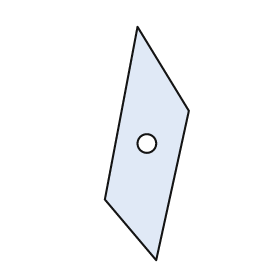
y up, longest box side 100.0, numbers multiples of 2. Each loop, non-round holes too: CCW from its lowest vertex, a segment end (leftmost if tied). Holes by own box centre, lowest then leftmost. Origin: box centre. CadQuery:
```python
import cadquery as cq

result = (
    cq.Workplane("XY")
    .moveTo(4.0, -50.0)
    .lineTo(18.0, 14.0)
    .lineTo(-4.0, 50.0)
    .lineTo(-18.0, -24.0)
    .close()
    .moveTo(0.0, 0.0)
    .circle(4.0)
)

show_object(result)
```